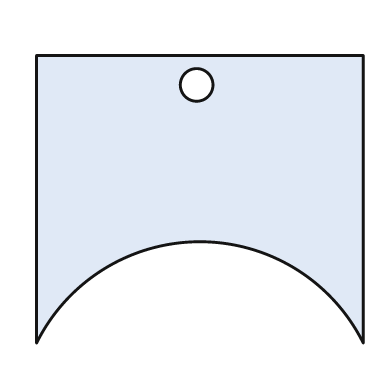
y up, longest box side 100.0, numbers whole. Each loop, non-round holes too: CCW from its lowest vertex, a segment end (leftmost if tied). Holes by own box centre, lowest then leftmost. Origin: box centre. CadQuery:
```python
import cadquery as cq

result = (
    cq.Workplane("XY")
    .moveTo(-50.0, -44.0)
    .threePointArc((0.0, -13.0), (50.0, -44.0))
    .lineTo(50.0, 44.0)
    .lineTo(-50.0, 44.0)
    .close()
    .moveTo(-1.0, 35.0)
    .circle(5.0)
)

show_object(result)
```